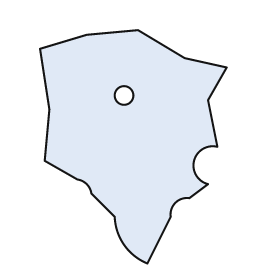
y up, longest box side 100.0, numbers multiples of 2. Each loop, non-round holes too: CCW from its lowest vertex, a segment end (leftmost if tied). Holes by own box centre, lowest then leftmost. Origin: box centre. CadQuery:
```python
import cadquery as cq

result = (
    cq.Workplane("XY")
    .moveTo(6.0, -50.0)
    .lineTo(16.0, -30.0)
    .threePointArc((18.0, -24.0), (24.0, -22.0))
    .lineTo(32.0, -16.0)
    .threePointArc((26.0, -6.0), (36.0, 0.0))
    .lineTo(32.0, 20.0)
    .lineTo(40.0, 34.0)
    .lineTo(22.0, 38.0)
    .lineTo(2.0, 50.0)
    .lineTo(-20.0, 48.0)
    .lineTo(-40.0, 42.0)
    .lineTo(-36.0, 16.0)
    .lineTo(-38.0, -6.0)
    .lineTo(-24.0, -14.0)
    .threePointArc((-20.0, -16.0), (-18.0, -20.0))
    .lineTo(-8.0, -30.0)
    .threePointArc((-4.0, -42.0), (6.0, -50.0))
    .close()
    .moveTo(-4.0, 22.0)
    .circle(4.0)
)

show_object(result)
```